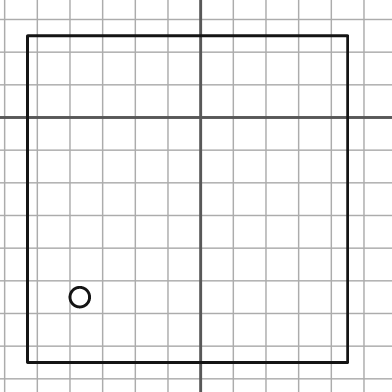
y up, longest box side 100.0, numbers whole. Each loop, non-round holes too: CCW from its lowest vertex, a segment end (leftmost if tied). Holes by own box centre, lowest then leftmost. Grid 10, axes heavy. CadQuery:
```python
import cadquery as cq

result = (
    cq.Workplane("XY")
    .moveTo(-53.0, -75.0)
    .lineTo(45.0, -75.0)
    .lineTo(45.0, 25.0)
    .lineTo(-53.0, 25.0)
    .close()
    .moveTo(-37.0, -55.0)
    .circle(3.0)
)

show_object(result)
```